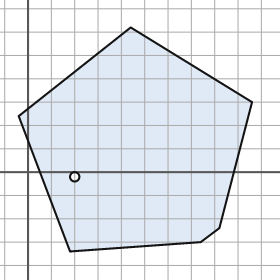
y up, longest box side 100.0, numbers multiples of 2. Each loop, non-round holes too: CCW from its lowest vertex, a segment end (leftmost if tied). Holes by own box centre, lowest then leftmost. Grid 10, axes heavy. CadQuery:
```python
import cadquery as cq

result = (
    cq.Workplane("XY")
    .moveTo(18.0, -34.0)
    .lineTo(74.0, -30.0)
    .lineTo(82.0, -24.0)
    .lineTo(96.0, 30.0)
    .lineTo(44.0, 62.0)
    .lineTo(-4.0, 24.0)
    .close()
    .moveTo(20.0, -2.0)
    .circle(2.0)
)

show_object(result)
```